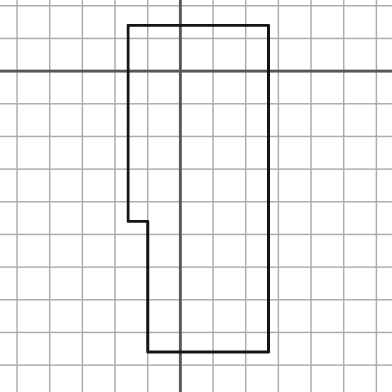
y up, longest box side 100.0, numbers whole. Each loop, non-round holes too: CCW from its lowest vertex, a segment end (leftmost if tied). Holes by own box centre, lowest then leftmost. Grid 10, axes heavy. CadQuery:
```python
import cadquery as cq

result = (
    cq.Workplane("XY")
    .moveTo(-10.0, -86.0)
    .lineTo(27.0, -86.0)
    .lineTo(27.0, 14.0)
    .lineTo(-16.0, 14.0)
    .lineTo(-16.0, -46.0)
    .lineTo(-10.0, -46.0)
    .close()
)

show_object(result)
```